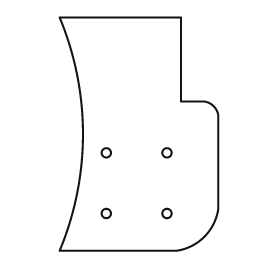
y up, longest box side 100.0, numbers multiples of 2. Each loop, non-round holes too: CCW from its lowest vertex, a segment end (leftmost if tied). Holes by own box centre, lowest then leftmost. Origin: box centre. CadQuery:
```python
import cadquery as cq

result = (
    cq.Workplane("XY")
    .moveTo(-34.0, -50.0)
    .lineTo(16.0, -50.0)
    .threePointArc((28.0, -44.0), (34.0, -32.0))
    .lineTo(34.0, 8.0)
    .threePointArc((32.0, 12.0), (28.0, 14.0))
    .lineTo(18.0, 14.0)
    .lineTo(18.0, 50.0)
    .lineTo(-34.0, 50.0)
    .threePointArc((-24.0, 0.0), (-34.0, -50.0))
    .close()
    .moveTo(-14.0, -34.0)
    .circle(2.0)
    .moveTo(12.0, -34.0)
    .circle(2.0)
    .moveTo(-14.0, -8.0)
    .circle(2.0)
    .moveTo(12.0, -8.0)
    .circle(2.0)
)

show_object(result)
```